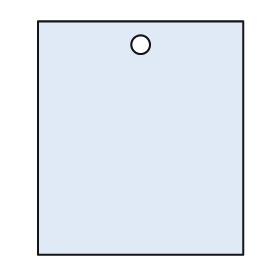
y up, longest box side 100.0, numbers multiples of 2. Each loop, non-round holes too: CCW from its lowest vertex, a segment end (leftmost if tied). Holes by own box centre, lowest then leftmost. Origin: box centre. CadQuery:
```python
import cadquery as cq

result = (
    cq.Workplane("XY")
    .moveTo(-44.0, -50.0)
    .lineTo(44.0, -50.0)
    .lineTo(44.0, 50.0)
    .lineTo(-44.0, 50.0)
    .close()
    .moveTo(0.0, 40.0)
    .circle(4.0)
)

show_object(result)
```